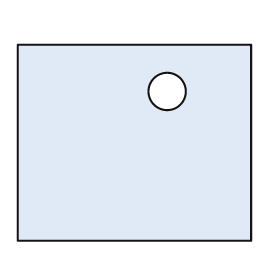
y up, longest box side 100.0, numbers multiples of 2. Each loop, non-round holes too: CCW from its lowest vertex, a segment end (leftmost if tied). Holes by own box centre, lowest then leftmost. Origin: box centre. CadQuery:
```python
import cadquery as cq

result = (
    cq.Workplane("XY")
    .moveTo(-50.0, -42.0)
    .lineTo(50.0, -42.0)
    .lineTo(50.0, 42.0)
    .lineTo(-50.0, 42.0)
    .close()
    .moveTo(14.0, 22.0)
    .circle(8.0)
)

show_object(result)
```